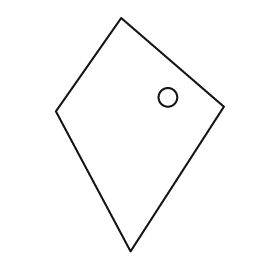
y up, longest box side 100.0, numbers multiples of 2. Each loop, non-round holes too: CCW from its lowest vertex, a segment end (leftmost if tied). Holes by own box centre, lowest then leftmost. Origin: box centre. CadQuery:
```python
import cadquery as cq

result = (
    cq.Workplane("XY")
    .moveTo(-4.0, -50.0)
    .lineTo(36.0, 12.0)
    .lineTo(-8.0, 50.0)
    .lineTo(-36.0, 10.0)
    .close()
    .moveTo(12.0, 16.0)
    .circle(4.0)
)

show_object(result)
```